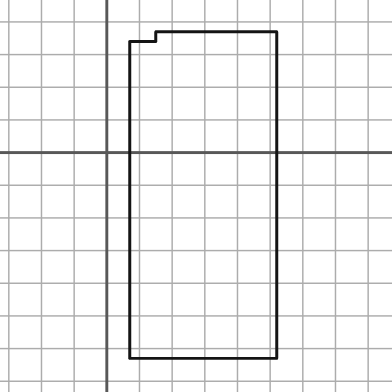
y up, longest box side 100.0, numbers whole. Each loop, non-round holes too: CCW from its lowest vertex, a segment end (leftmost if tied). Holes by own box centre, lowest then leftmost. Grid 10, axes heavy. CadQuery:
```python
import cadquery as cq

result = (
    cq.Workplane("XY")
    .moveTo(7.0, -63.0)
    .lineTo(52.0, -63.0)
    .lineTo(52.0, 37.0)
    .lineTo(15.0, 37.0)
    .lineTo(15.0, 34.0)
    .lineTo(7.0, 34.0)
    .close()
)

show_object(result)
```